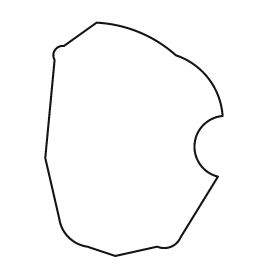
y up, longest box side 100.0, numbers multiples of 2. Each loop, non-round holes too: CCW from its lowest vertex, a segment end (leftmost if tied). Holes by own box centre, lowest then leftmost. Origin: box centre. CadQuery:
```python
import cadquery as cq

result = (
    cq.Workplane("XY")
    .moveTo(-8.0, -50.0)
    .lineTo(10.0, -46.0)
    .threePointArc((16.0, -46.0), (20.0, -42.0))
    .lineTo(36.0, -16.0)
    .threePointArc((26.0, -2.0), (38.0, 10.0))
    .threePointArc((32.0, 26.0), (18.0, 36.0))
    .threePointArc((2.0, 46.0), (-16.0, 50.0))
    .lineTo(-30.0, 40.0)
    .threePointArc((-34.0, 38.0), (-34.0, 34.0))
    .lineTo(-38.0, -8.0)
    .lineTo(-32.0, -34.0)
    .threePointArc((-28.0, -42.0), (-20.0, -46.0))
    .close()
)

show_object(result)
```